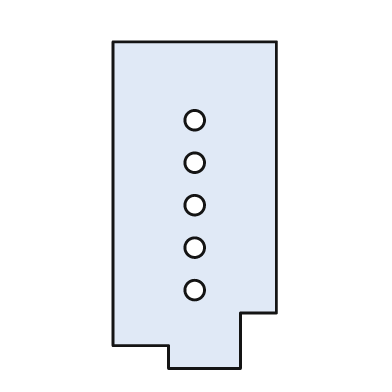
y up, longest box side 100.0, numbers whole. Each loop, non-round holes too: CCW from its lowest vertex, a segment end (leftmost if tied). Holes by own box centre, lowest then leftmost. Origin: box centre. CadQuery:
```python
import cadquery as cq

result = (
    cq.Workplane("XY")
    .moveTo(-8.0, -50.0)
    .lineTo(14.0, -50.0)
    .lineTo(14.0, -33.0)
    .lineTo(25.0, -33.0)
    .lineTo(25.0, 50.0)
    .lineTo(-25.0, 50.0)
    .lineTo(-25.0, -43.0)
    .lineTo(-8.0, -43.0)
    .close()
    .moveTo(0.0, -26.0)
    .circle(3.0)
    .moveTo(0.0, -13.0)
    .circle(3.0)
    .moveTo(0.0, 0.0)
    .circle(3.0)
    .moveTo(0.0, 13.0)
    .circle(3.0)
    .moveTo(0.0, 26.0)
    .circle(3.0)
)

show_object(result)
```